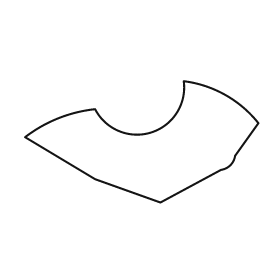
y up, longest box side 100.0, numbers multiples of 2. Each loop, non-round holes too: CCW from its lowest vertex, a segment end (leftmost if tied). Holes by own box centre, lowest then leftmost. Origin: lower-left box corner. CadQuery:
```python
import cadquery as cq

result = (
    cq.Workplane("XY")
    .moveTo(58.0, 0.0)
    .lineTo(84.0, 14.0)
    .threePointArc((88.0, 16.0), (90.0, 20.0))
    .lineTo(100.0, 34.0)
    .threePointArc((86.0, 46.0), (68.0, 52.0))
    .threePointArc((54.0, 30.0), (30.0, 40.0))
    .threePointArc((14.0, 36.0), (0.0, 28.0))
    .lineTo(30.0, 10.0)
    .close()
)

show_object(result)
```